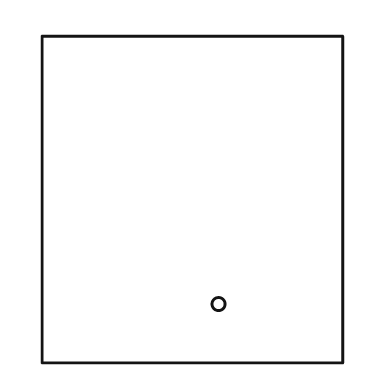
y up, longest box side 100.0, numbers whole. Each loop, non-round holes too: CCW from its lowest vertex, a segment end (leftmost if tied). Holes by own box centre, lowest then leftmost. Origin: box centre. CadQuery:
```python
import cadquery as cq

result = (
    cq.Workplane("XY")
    .moveTo(-46.0, -50.0)
    .lineTo(46.0, -50.0)
    .lineTo(46.0, 50.0)
    .lineTo(-46.0, 50.0)
    .close()
    .moveTo(8.0, -32.0)
    .circle(2.0)
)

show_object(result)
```